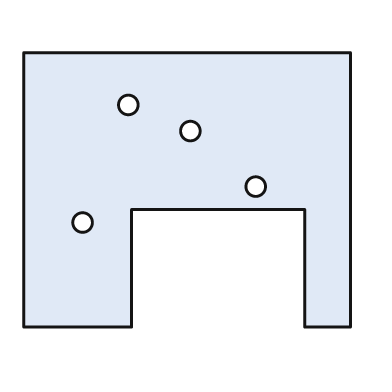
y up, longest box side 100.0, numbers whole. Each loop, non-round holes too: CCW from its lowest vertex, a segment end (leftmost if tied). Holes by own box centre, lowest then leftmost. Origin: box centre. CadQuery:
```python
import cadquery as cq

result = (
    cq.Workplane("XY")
    .moveTo(-50.0, -42.0)
    .lineTo(-17.0, -42.0)
    .lineTo(-17.0, -6.0)
    .lineTo(36.0, -6.0)
    .lineTo(36.0, -42.0)
    .lineTo(50.0, -42.0)
    .lineTo(50.0, 42.0)
    .lineTo(-50.0, 42.0)
    .close()
    .moveTo(-32.0, -10.0)
    .circle(3.0)
    .moveTo(21.0, 1.0)
    .circle(3.0)
    .moveTo(1.0, 18.0)
    .circle(3.0)
    .moveTo(-18.0, 26.0)
    .circle(3.0)
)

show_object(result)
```